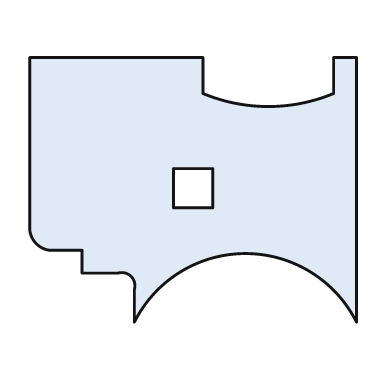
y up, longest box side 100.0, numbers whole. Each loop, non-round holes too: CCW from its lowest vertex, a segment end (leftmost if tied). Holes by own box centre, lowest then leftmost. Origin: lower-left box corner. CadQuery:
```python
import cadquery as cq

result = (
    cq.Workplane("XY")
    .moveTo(32.0, 0.0)
    .threePointArc((66.0, 21.0), (100.0, 0.0))
    .lineTo(100.0, 81.0)
    .lineTo(93.0, 81.0)
    .lineTo(93.0, 70.0)
    .threePointArc((73.0, 66.0), (53.0, 70.0))
    .lineTo(53.0, 81.0)
    .lineTo(0.0, 81.0)
    .lineTo(0.0, 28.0)
    .threePointArc((2.0, 24.0), (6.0, 22.0))
    .lineTo(16.0, 22.0)
    .lineTo(16.0, 15.0)
    .lineTo(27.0, 15.0)
    .threePointArc((31.0, 14.0), (32.0, 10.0))
    .close()
    .moveTo(44.0, 35.0)
    .lineTo(56.0, 35.0)
    .lineTo(56.0, 47.0)
    .lineTo(44.0, 47.0)
    .close()
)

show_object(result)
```